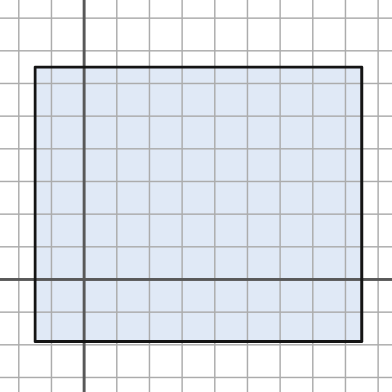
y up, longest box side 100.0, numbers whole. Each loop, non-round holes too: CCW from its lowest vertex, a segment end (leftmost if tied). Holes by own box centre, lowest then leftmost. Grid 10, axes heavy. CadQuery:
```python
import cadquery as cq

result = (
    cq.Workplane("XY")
    .moveTo(-15.0, -19.0)
    .lineTo(85.0, -19.0)
    .lineTo(85.0, 65.0)
    .lineTo(-15.0, 65.0)
    .close()
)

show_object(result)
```